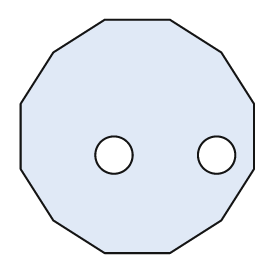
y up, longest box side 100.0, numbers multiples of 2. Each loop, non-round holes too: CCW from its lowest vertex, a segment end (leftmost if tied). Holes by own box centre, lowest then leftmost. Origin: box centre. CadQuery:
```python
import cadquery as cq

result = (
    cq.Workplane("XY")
    .moveTo(-14.0, -50.0)
    .lineTo(14.0, -50.0)
    .lineTo(36.0, -36.0)
    .lineTo(50.0, -14.0)
    .lineTo(50.0, 14.0)
    .lineTo(36.0, 36.0)
    .lineTo(14.0, 50.0)
    .lineTo(-14.0, 50.0)
    .lineTo(-36.0, 36.0)
    .lineTo(-50.0, 14.0)
    .lineTo(-50.0, -14.0)
    .lineTo(-36.0, -36.0)
    .close()
    .moveTo(-10.0, -8.0)
    .circle(8.0)
    .moveTo(34.0, -8.0)
    .circle(8.0)
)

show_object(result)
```